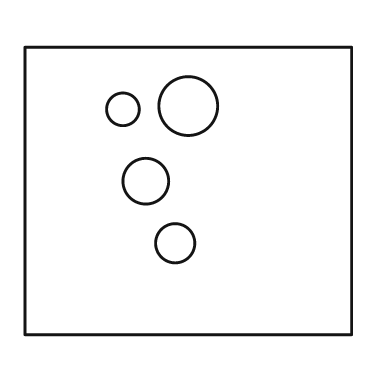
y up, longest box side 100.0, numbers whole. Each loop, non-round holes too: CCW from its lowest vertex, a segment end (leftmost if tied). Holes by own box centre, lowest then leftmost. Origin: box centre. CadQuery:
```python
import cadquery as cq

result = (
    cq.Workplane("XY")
    .moveTo(-50.0, -44.0)
    .lineTo(50.0, -44.0)
    .lineTo(50.0, 44.0)
    .lineTo(-50.0, 44.0)
    .close()
    .moveTo(-4.0, -16.0)
    .circle(6.0)
    .moveTo(-13.0, 3.0)
    .circle(7.0)
    .moveTo(-20.0, 25.0)
    .circle(5.0)
    .moveTo(0.0, 26.0)
    .circle(9.0)
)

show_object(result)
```